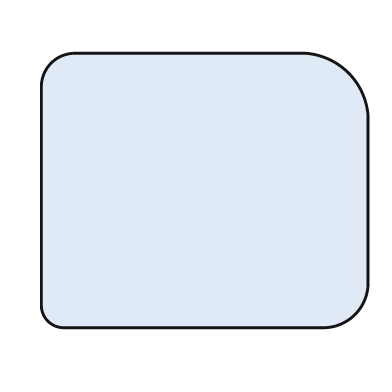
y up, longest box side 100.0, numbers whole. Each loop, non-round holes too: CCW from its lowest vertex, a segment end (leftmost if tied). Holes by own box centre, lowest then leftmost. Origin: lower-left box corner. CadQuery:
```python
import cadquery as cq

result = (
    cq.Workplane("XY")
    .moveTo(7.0, 0.0)
    .lineTo(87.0, 0.0)
    .threePointArc((96.0, 4.0), (100.0, 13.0))
    .lineTo(100.0, 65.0)
    .threePointArc((94.0, 78.0), (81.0, 84.0))
    .lineTo(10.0, 84.0)
    .threePointArc((3.0, 81.0), (0.0, 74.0))
    .lineTo(0.0, 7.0)
    .threePointArc((2.0, 2.0), (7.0, 0.0))
    .close()
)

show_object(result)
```